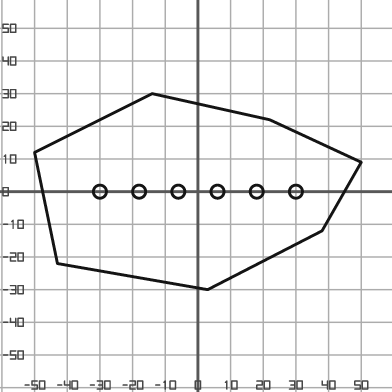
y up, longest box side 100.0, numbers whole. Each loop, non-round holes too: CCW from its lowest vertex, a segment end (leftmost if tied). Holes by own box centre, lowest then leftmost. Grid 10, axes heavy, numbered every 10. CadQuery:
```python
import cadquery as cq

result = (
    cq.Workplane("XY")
    .moveTo(3.0, -30.0)
    .lineTo(38.0, -12.0)
    .lineTo(50.0, 9.0)
    .lineTo(22.0, 22.0)
    .lineTo(-14.0, 30.0)
    .lineTo(-50.0, 12.0)
    .lineTo(-43.0, -22.0)
    .close()
    .moveTo(-30.0, 0.0)
    .circle(2.0)
    .moveTo(-18.0, 0.0)
    .circle(2.0)
    .moveTo(-6.0, 0.0)
    .circle(2.0)
    .moveTo(6.0, 0.0)
    .circle(2.0)
    .moveTo(18.0, 0.0)
    .circle(2.0)
    .moveTo(30.0, 0.0)
    .circle(2.0)
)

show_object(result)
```